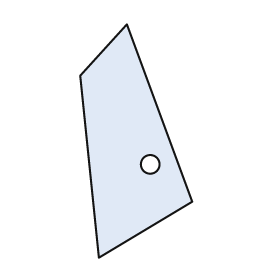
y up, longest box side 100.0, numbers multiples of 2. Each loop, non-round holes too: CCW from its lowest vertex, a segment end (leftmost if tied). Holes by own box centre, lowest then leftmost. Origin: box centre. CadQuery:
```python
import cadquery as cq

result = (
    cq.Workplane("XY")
    .moveTo(-16.0, -50.0)
    .lineTo(24.0, -26.0)
    .lineTo(-4.0, 50.0)
    .lineTo(-24.0, 28.0)
    .close()
    .moveTo(6.0, -10.0)
    .circle(4.0)
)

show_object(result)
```